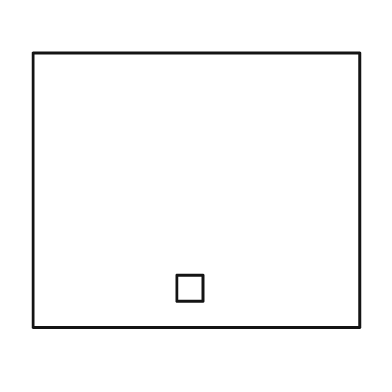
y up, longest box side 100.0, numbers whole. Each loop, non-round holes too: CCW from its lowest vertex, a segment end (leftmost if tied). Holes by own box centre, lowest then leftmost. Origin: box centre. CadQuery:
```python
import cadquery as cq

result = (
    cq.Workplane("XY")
    .moveTo(-50.0, -42.0)
    .lineTo(50.0, -42.0)
    .lineTo(50.0, 42.0)
    .lineTo(-50.0, 42.0)
    .close()
    .moveTo(-6.0, -34.0)
    .lineTo(2.0, -34.0)
    .lineTo(2.0, -26.0)
    .lineTo(-6.0, -26.0)
    .close()
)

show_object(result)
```